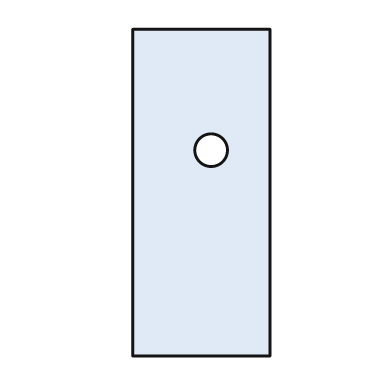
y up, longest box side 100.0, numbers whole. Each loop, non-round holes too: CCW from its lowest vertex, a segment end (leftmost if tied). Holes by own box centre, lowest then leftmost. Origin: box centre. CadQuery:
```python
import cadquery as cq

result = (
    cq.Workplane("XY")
    .moveTo(-21.0, -50.0)
    .lineTo(21.0, -50.0)
    .lineTo(21.0, 50.0)
    .lineTo(-21.0, 50.0)
    .close()
    .moveTo(3.0, 13.0)
    .circle(5.0)
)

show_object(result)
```